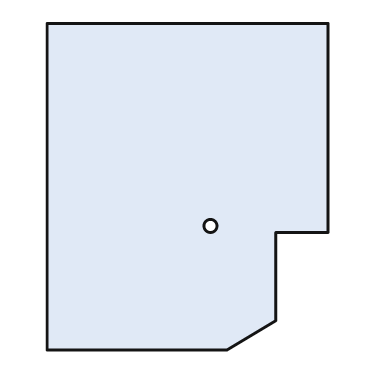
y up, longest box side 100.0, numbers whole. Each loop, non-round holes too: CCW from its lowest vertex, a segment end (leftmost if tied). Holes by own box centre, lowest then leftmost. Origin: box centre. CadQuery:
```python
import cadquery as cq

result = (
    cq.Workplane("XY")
    .moveTo(-43.0, -50.0)
    .lineTo(12.0, -50.0)
    .lineTo(27.0, -41.0)
    .lineTo(27.0, -14.0)
    .lineTo(43.0, -14.0)
    .lineTo(43.0, 50.0)
    .lineTo(-43.0, 50.0)
    .close()
    .moveTo(7.0, -12.0)
    .circle(2.0)
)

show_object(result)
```